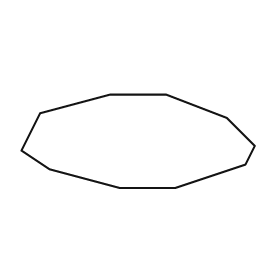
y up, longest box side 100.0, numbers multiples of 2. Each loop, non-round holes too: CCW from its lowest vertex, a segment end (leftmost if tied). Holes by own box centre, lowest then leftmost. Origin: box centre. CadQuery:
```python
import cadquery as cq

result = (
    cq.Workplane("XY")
    .moveTo(-8.0, -20.0)
    .lineTo(16.0, -20.0)
    .lineTo(46.0, -10.0)
    .lineTo(50.0, -2.0)
    .lineTo(38.0, 10.0)
    .lineTo(12.0, 20.0)
    .lineTo(-12.0, 20.0)
    .lineTo(-42.0, 12.0)
    .lineTo(-50.0, -4.0)
    .lineTo(-38.0, -12.0)
    .close()
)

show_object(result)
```